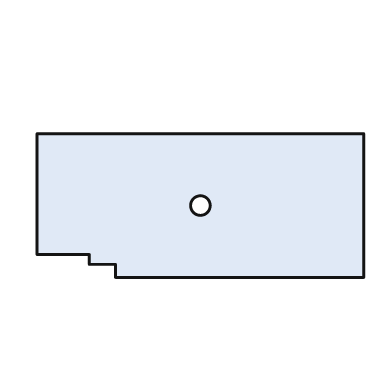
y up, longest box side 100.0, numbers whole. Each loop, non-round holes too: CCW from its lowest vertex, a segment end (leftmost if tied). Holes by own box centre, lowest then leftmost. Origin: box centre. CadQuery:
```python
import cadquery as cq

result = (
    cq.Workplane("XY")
    .moveTo(-26.0, -22.0)
    .lineTo(50.0, -22.0)
    .lineTo(50.0, 22.0)
    .lineTo(-50.0, 22.0)
    .lineTo(-50.0, -15.0)
    .lineTo(-34.0, -15.0)
    .lineTo(-34.0, -18.0)
    .lineTo(-26.0, -18.0)
    .close()
    .moveTo(0.0, 0.0)
    .circle(3.0)
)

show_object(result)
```